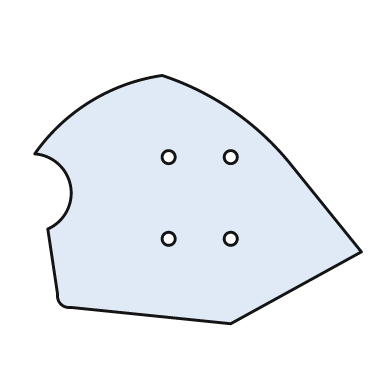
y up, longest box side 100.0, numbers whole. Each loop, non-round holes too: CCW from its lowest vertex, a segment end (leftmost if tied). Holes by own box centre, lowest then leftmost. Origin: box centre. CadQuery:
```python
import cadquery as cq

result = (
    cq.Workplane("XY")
    .moveTo(10.0, -38.0)
    .lineTo(50.0, -16.0)
    .lineTo(29.0, 10.0)
    .threePointArc((11.0, 27.0), (-11.0, 38.0))
    .threePointArc((-33.0, 30.0), (-50.0, 14.0))
    .threePointArc((-39.0, 4.0), (-46.0, -9.0))
    .lineTo(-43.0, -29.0)
    .threePointArc((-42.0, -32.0), (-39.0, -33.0))
    .close()
    .moveTo(-9.0, -12.0)
    .circle(2.0)
    .moveTo(10.0, -12.0)
    .circle(2.0)
    .moveTo(-9.0, 13.0)
    .circle(2.0)
    .moveTo(10.0, 13.0)
    .circle(2.0)
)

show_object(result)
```